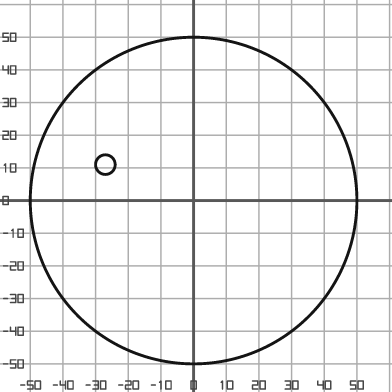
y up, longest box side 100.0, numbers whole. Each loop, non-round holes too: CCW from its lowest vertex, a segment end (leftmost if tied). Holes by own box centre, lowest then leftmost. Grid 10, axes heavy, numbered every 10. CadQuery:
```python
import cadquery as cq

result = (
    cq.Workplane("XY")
    .moveTo(0.0, 0.0)
    .circle(50.0)
    .moveTo(-27.0, 11.0)
    .circle(3.0)
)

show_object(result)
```